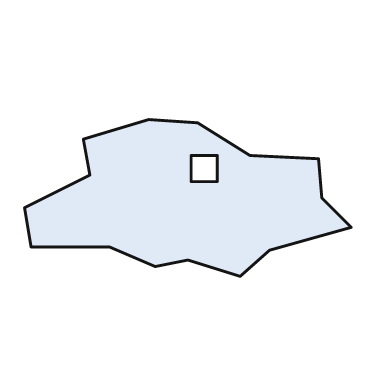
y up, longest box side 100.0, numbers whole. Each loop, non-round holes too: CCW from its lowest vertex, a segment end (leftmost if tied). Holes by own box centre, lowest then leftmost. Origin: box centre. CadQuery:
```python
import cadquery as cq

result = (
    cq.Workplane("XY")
    .moveTo(16.0, -24.0)
    .lineTo(25.0, -16.0)
    .lineTo(50.0, -9.0)
    .lineTo(41.0, 0.0)
    .lineTo(40.0, 12.0)
    .lineTo(19.0, 13.0)
    .lineTo(3.0, 23.0)
    .lineTo(-12.0, 24.0)
    .lineTo(-32.0, 18.0)
    .lineTo(-30.0, 7.0)
    .lineTo(-50.0, -3.0)
    .lineTo(-48.0, -15.0)
    .lineTo(-24.0, -15.0)
    .lineTo(-10.0, -21.0)
    .lineTo(0.0, -19.0)
    .close()
    .moveTo(1.0, 5.0)
    .lineTo(9.0, 5.0)
    .lineTo(9.0, 13.0)
    .lineTo(1.0, 13.0)
    .close()
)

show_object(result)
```